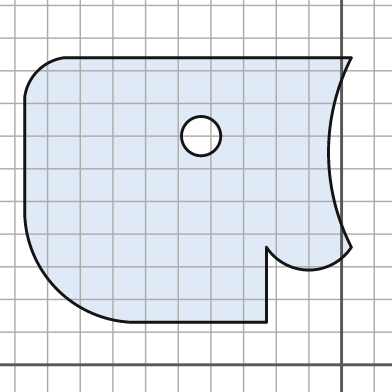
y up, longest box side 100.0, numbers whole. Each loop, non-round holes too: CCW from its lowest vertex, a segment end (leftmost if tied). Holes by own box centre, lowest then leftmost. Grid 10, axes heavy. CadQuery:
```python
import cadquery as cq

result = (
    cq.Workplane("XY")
    .moveTo(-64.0, 13.0)
    .lineTo(-23.0, 13.0)
    .lineTo(-23.0, 36.0)
    .threePointArc((-10.0, 29.0), (3.0, 36.0))
    .threePointArc((-4.0, 65.0), (3.0, 94.0))
    .lineTo(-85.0, 94.0)
    .threePointArc((-93.0, 90.0), (-97.0, 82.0))
    .lineTo(-97.0, 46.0)
    .threePointArc((-87.0, 23.0), (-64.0, 13.0))
    .close()
    .moveTo(-43.0, 70.0)
    .circle(6.0)
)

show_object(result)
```